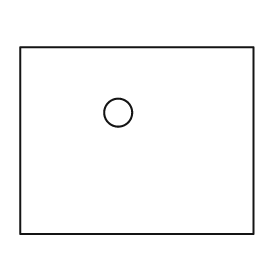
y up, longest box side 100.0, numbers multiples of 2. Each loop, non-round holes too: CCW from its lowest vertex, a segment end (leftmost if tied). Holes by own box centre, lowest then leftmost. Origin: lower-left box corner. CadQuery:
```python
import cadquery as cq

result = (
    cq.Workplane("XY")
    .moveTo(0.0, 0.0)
    .lineTo(100.0, 0.0)
    .lineTo(100.0, 80.0)
    .lineTo(0.0, 80.0)
    .close()
    .moveTo(42.0, 52.0)
    .circle(6.0)
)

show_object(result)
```